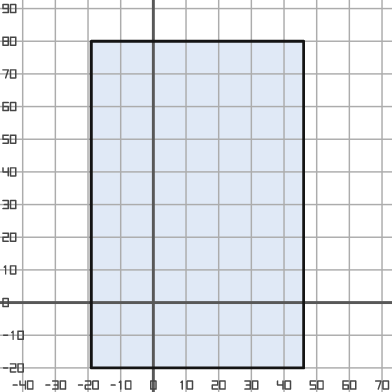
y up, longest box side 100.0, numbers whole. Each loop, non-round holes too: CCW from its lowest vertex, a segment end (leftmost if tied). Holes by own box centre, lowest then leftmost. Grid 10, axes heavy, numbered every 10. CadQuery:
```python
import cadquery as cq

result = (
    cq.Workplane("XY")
    .moveTo(-19.0, -20.0)
    .lineTo(46.0, -20.0)
    .lineTo(46.0, 80.0)
    .lineTo(-19.0, 80.0)
    .close()
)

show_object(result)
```